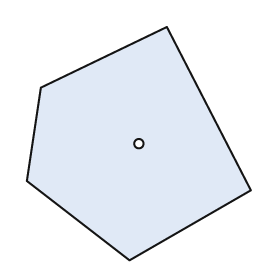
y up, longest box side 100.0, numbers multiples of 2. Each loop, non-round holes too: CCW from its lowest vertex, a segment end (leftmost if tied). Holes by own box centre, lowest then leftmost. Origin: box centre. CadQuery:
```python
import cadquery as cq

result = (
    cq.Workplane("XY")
    .moveTo(-4.0, -50.0)
    .lineTo(48.0, -20.0)
    .lineTo(12.0, 50.0)
    .lineTo(-42.0, 24.0)
    .lineTo(-48.0, -16.0)
    .close()
    .moveTo(0.0, 0.0)
    .circle(2.0)
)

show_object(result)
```